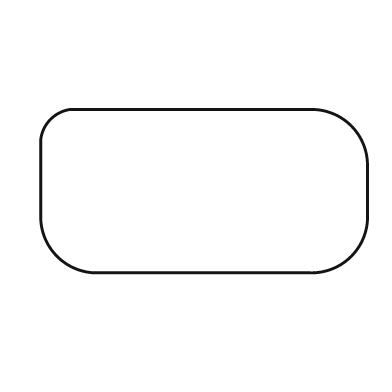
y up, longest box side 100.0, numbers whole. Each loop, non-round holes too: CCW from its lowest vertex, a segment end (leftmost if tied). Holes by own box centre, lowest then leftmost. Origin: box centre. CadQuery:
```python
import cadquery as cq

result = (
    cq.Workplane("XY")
    .moveTo(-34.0, -25.0)
    .lineTo(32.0, -25.0)
    .threePointArc((45.0, -20.0), (50.0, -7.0))
    .lineTo(50.0, 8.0)
    .threePointArc((45.0, 20.0), (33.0, 25.0))
    .lineTo(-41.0, 25.0)
    .threePointArc((-47.0, 22.0), (-50.0, 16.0))
    .lineTo(-50.0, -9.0)
    .threePointArc((-45.0, -20.0), (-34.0, -25.0))
    .close()
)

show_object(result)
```